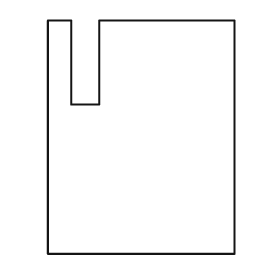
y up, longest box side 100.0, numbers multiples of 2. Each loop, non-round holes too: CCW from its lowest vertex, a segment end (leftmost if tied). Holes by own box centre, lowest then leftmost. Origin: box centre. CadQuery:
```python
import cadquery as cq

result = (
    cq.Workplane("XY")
    .moveTo(-40.0, -50.0)
    .lineTo(40.0, -50.0)
    .lineTo(40.0, 50.0)
    .lineTo(-18.0, 50.0)
    .lineTo(-18.0, 14.0)
    .lineTo(-30.0, 14.0)
    .lineTo(-30.0, 50.0)
    .lineTo(-40.0, 50.0)
    .close()
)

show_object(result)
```